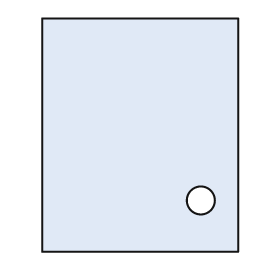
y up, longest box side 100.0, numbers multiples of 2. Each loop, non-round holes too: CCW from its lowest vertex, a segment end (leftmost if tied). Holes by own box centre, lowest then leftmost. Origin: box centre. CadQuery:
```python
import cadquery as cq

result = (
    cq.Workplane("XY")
    .moveTo(-42.0, -50.0)
    .lineTo(42.0, -50.0)
    .lineTo(42.0, 50.0)
    .lineTo(-42.0, 50.0)
    .close()
    .moveTo(26.0, -28.0)
    .circle(6.0)
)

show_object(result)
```